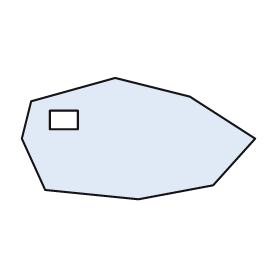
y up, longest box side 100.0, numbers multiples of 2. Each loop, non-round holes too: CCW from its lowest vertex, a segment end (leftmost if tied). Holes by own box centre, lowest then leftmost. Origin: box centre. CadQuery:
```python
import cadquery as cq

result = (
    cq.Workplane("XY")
    .moveTo(0.0, -26.0)
    .lineTo(32.0, -20.0)
    .lineTo(50.0, 0.0)
    .lineTo(22.0, 18.0)
    .lineTo(-10.0, 26.0)
    .lineTo(-46.0, 16.0)
    .lineTo(-50.0, 0.0)
    .lineTo(-40.0, -22.0)
    .close()
    .moveTo(-38.0, 4.0)
    .lineTo(-26.0, 4.0)
    .lineTo(-26.0, 12.0)
    .lineTo(-38.0, 12.0)
    .close()
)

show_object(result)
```